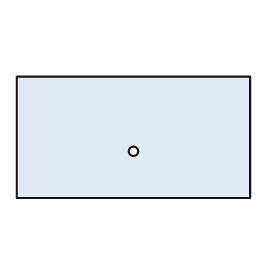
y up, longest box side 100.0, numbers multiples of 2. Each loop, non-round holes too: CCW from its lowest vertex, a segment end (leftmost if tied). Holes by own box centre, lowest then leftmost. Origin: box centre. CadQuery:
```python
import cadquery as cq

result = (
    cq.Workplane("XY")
    .moveTo(-50.0, -26.0)
    .lineTo(50.0, -26.0)
    .lineTo(50.0, 26.0)
    .lineTo(-50.0, 26.0)
    .close()
    .moveTo(0.0, -6.0)
    .circle(2.0)
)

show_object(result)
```